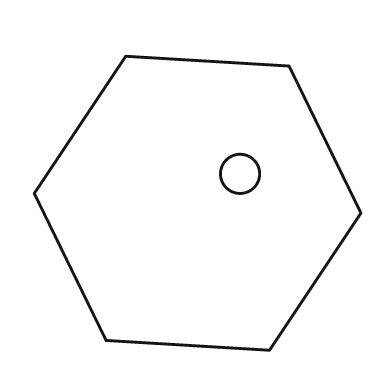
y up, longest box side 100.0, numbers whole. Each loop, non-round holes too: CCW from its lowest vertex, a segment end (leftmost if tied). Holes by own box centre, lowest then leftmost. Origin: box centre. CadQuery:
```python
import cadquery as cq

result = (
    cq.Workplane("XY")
    .moveTo(22.0, -45.0)
    .lineTo(50.0, -3.0)
    .lineTo(28.0, 42.0)
    .lineTo(-22.0, 45.0)
    .lineTo(-50.0, 3.0)
    .lineTo(-28.0, -42.0)
    .close()
    .moveTo(13.0, 9.0)
    .circle(6.0)
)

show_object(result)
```